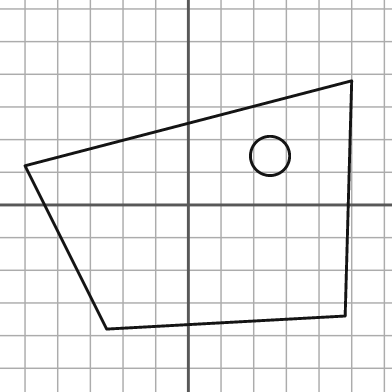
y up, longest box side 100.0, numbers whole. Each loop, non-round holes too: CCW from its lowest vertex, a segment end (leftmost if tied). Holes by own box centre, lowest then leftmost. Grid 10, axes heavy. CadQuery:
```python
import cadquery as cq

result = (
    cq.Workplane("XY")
    .moveTo(-25.0, -38.0)
    .lineTo(48.0, -34.0)
    .lineTo(50.0, 38.0)
    .lineTo(-50.0, 12.0)
    .close()
    .moveTo(25.0, 15.0)
    .circle(6.0)
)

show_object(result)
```